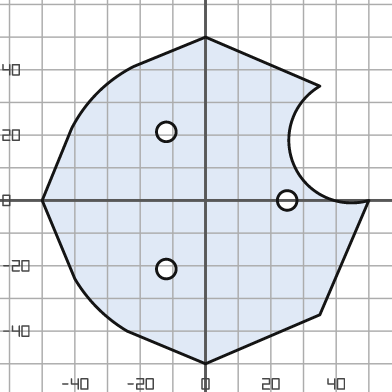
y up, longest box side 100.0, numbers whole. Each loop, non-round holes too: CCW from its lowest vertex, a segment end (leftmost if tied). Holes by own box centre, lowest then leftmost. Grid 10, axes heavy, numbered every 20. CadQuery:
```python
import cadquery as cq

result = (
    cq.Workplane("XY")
    .moveTo(0.0, -50.0)
    .lineTo(35.0, -35.0)
    .lineTo(50.0, 0.0)
    .threePointArc((27.0, 11.0), (35.0, 35.0))
    .lineTo(0.0, 50.0)
    .lineTo(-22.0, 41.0)
    .threePointArc((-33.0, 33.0), (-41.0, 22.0))
    .lineTo(-50.0, 0.0)
    .lineTo(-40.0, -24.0)
    .threePointArc((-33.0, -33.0), (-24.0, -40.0))
    .close()
    .moveTo(-12.0, -21.0)
    .circle(3.0)
    .moveTo(25.0, 0.0)
    .circle(3.0)
    .moveTo(-12.0, 21.0)
    .circle(3.0)
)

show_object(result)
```